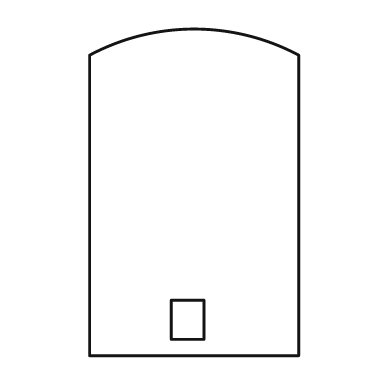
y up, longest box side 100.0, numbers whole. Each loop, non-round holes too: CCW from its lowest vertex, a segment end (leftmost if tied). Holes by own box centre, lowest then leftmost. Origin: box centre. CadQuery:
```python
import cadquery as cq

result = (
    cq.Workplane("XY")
    .moveTo(-32.0, -50.0)
    .lineTo(32.0, -50.0)
    .lineTo(32.0, 42.0)
    .threePointArc((0.0, 50.0), (-32.0, 42.0))
    .close()
    .moveTo(-7.0, -45.0)
    .lineTo(3.0, -45.0)
    .lineTo(3.0, -33.0)
    .lineTo(-7.0, -33.0)
    .close()
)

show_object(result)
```